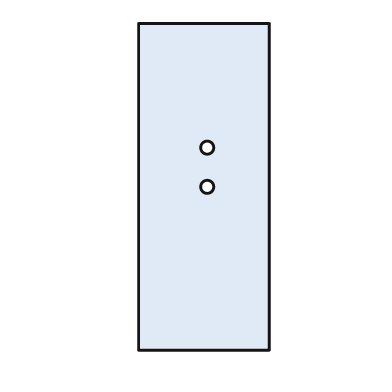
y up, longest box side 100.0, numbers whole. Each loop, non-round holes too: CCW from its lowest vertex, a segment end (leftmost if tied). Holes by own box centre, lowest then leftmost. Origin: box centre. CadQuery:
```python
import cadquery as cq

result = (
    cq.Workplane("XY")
    .moveTo(-20.0, -50.0)
    .lineTo(20.0, -50.0)
    .lineTo(20.0, 50.0)
    .lineTo(-20.0, 50.0)
    .close()
    .moveTo(1.0, 0.0)
    .circle(2.0)
    .moveTo(1.0, 12.0)
    .circle(2.0)
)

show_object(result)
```